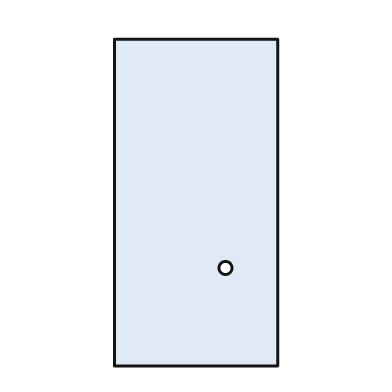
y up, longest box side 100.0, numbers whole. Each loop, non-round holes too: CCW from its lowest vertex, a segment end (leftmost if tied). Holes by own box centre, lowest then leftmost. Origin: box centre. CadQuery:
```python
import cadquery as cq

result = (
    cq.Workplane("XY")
    .moveTo(-25.0, -50.0)
    .lineTo(25.0, -50.0)
    .lineTo(25.0, 50.0)
    .lineTo(-25.0, 50.0)
    .close()
    .moveTo(9.0, -20.0)
    .circle(2.0)
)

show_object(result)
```